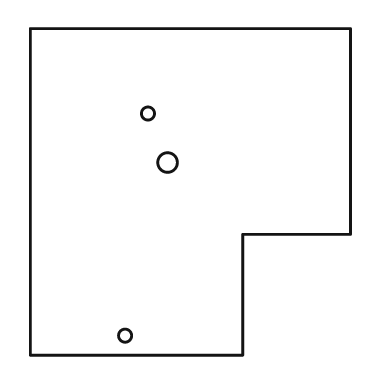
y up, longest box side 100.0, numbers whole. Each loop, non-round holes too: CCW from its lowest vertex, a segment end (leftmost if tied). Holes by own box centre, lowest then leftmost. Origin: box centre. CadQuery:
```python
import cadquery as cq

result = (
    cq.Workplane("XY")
    .moveTo(-49.0, -50.0)
    .lineTo(16.0, -50.0)
    .lineTo(16.0, -13.0)
    .lineTo(49.0, -13.0)
    .lineTo(49.0, 50.0)
    .lineTo(-49.0, 50.0)
    .close()
    .moveTo(-20.0, -44.0)
    .circle(2.0)
    .moveTo(-7.0, 9.0)
    .circle(3.0)
    .moveTo(-13.0, 24.0)
    .circle(2.0)
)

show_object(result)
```